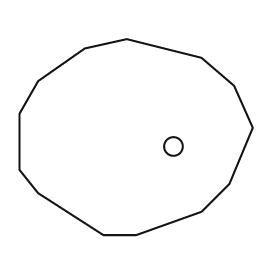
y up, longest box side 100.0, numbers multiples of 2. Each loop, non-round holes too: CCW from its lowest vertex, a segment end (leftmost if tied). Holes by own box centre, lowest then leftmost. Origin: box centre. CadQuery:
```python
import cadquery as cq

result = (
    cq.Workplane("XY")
    .moveTo(-14.0, -42.0)
    .lineTo(0.0, -42.0)
    .lineTo(28.0, -32.0)
    .lineTo(40.0, -20.0)
    .lineTo(50.0, 4.0)
    .lineTo(42.0, 22.0)
    .lineTo(28.0, 34.0)
    .lineTo(-4.0, 42.0)
    .lineTo(-22.0, 38.0)
    .lineTo(-42.0, 24.0)
    .lineTo(-50.0, 10.0)
    .lineTo(-50.0, -14.0)
    .lineTo(-42.0, -24.0)
    .close()
    .moveTo(16.0, -4.0)
    .circle(4.0)
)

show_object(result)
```